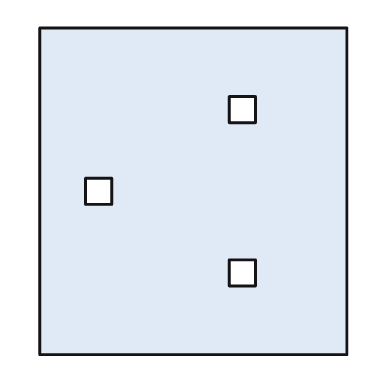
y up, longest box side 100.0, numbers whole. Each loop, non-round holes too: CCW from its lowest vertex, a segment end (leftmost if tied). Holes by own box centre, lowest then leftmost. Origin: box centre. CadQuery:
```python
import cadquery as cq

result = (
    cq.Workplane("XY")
    .moveTo(-47.0, -50.0)
    .lineTo(47.0, -50.0)
    .lineTo(47.0, 50.0)
    .lineTo(-47.0, 50.0)
    .close()
    .moveTo(11.0, -29.0)
    .lineTo(19.0, -29.0)
    .lineTo(19.0, -21.0)
    .lineTo(11.0, -21.0)
    .close()
    .moveTo(-33.0, -4.0)
    .lineTo(-25.0, -4.0)
    .lineTo(-25.0, 4.0)
    .lineTo(-33.0, 4.0)
    .close()
    .moveTo(11.0, 21.0)
    .lineTo(19.0, 21.0)
    .lineTo(19.0, 29.0)
    .lineTo(11.0, 29.0)
    .close()
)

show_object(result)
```